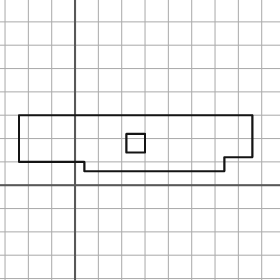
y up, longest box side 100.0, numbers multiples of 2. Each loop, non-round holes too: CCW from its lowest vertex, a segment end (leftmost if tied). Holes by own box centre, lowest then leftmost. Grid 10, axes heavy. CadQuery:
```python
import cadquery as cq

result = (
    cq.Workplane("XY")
    .moveTo(4.0, 6.0)
    .lineTo(64.0, 6.0)
    .lineTo(64.0, 12.0)
    .lineTo(76.0, 12.0)
    .lineTo(76.0, 30.0)
    .lineTo(-24.0, 30.0)
    .lineTo(-24.0, 10.0)
    .lineTo(4.0, 10.0)
    .close()
    .moveTo(22.0, 14.0)
    .lineTo(30.0, 14.0)
    .lineTo(30.0, 22.0)
    .lineTo(22.0, 22.0)
    .close()
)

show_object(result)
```